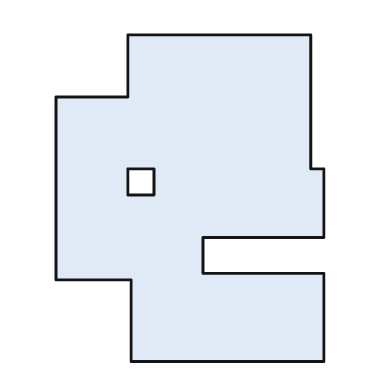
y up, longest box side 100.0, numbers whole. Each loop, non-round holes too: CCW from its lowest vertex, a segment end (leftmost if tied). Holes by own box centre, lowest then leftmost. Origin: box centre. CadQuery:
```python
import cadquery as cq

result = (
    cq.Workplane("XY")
    .moveTo(-18.0, -50.0)
    .lineTo(41.0, -50.0)
    .lineTo(41.0, -23.0)
    .lineTo(4.0, -23.0)
    .lineTo(4.0, -12.0)
    .lineTo(41.0, -12.0)
    .lineTo(41.0, 9.0)
    .lineTo(37.0, 9.0)
    .lineTo(37.0, 50.0)
    .lineTo(-19.0, 50.0)
    .lineTo(-19.0, 31.0)
    .lineTo(-41.0, 31.0)
    .lineTo(-41.0, -25.0)
    .lineTo(-18.0, -25.0)
    .close()
    .moveTo(-19.0, 1.0)
    .lineTo(-11.0, 1.0)
    .lineTo(-11.0, 9.0)
    .lineTo(-19.0, 9.0)
    .close()
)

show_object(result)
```